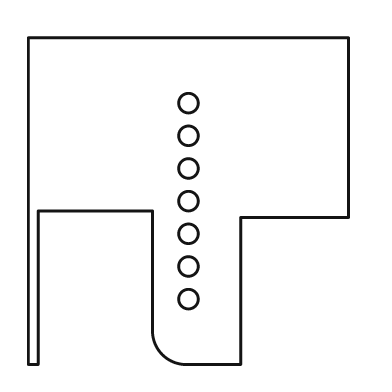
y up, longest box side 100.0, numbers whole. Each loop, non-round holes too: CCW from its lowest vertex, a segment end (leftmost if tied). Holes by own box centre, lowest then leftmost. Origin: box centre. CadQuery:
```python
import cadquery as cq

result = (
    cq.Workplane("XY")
    .moveTo(-49.0, -50.0)
    .lineTo(-46.0, -50.0)
    .lineTo(-46.0, -3.0)
    .lineTo(-11.0, -3.0)
    .lineTo(-11.0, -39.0)
    .threePointArc((-8.0, -47.0), (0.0, -50.0))
    .lineTo(16.0, -50.0)
    .lineTo(16.0, -5.0)
    .lineTo(49.0, -5.0)
    .lineTo(49.0, 50.0)
    .lineTo(-49.0, 50.0)
    .close()
    .moveTo(0.0, -30.0)
    .circle(3.0)
    .moveTo(0.0, -20.0)
    .circle(3.0)
    .moveTo(0.0, -10.0)
    .circle(3.0)
    .moveTo(0.0, 0.0)
    .circle(3.0)
    .moveTo(0.0, 10.0)
    .circle(3.0)
    .moveTo(0.0, 20.0)
    .circle(3.0)
    .moveTo(0.0, 30.0)
    .circle(3.0)
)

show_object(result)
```